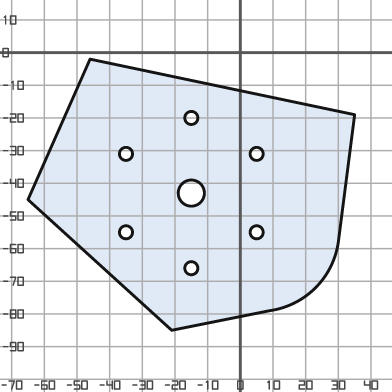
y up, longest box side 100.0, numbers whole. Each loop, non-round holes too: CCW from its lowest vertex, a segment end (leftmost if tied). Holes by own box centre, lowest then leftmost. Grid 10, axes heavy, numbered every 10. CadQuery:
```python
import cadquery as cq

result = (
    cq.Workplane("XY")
    .moveTo(-21.0, -85.0)
    .lineTo(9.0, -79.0)
    .threePointArc((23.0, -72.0), (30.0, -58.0))
    .lineTo(35.0, -19.0)
    .lineTo(-46.0, -2.0)
    .lineTo(-65.0, -45.0)
    .close()
    .moveTo(-15.0, -66.0)
    .circle(2.0)
    .moveTo(-35.0, -55.0)
    .circle(2.0)
    .moveTo(5.0, -55.0)
    .circle(2.0)
    .moveTo(-15.0, -43.0)
    .circle(4.0)
    .moveTo(-35.0, -31.0)
    .circle(2.0)
    .moveTo(5.0, -31.0)
    .circle(2.0)
    .moveTo(-15.0, -20.0)
    .circle(2.0)
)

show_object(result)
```